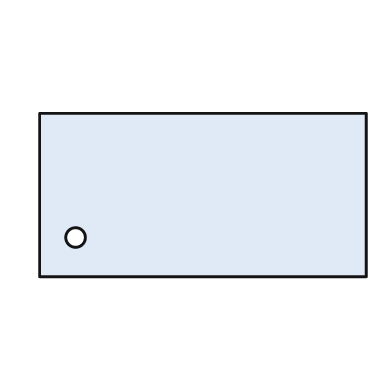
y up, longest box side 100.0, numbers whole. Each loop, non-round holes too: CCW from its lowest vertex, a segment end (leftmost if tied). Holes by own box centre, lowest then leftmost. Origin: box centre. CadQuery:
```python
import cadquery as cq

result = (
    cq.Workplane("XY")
    .moveTo(-50.0, -25.0)
    .lineTo(50.0, -25.0)
    .lineTo(50.0, 25.0)
    .lineTo(-50.0, 25.0)
    .close()
    .moveTo(-39.0, -13.0)
    .circle(3.0)
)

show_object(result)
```